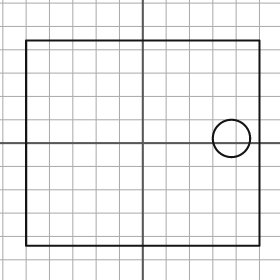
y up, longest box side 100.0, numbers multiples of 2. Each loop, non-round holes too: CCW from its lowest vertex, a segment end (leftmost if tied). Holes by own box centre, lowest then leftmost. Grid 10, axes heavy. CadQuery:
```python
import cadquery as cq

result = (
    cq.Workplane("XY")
    .moveTo(-50.0, -44.0)
    .lineTo(50.0, -44.0)
    .lineTo(50.0, 44.0)
    .lineTo(-50.0, 44.0)
    .close()
    .moveTo(38.0, 2.0)
    .circle(8.0)
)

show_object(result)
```